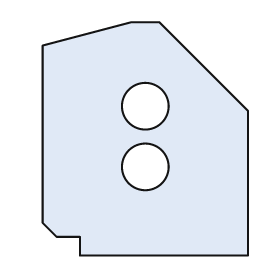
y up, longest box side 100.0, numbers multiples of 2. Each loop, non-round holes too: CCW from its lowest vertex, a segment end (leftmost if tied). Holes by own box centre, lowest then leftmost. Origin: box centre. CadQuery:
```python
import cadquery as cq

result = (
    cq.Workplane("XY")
    .moveTo(-28.0, -50.0)
    .lineTo(44.0, -50.0)
    .lineTo(44.0, 12.0)
    .lineTo(6.0, 50.0)
    .lineTo(-6.0, 50.0)
    .lineTo(-44.0, 40.0)
    .lineTo(-44.0, -36.0)
    .lineTo(-38.0, -42.0)
    .lineTo(-28.0, -42.0)
    .close()
    .moveTo(0.0, -12.0)
    .circle(10.0)
    .moveTo(0.0, 14.0)
    .circle(10.0)
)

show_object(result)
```